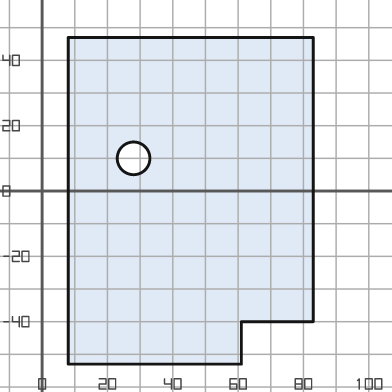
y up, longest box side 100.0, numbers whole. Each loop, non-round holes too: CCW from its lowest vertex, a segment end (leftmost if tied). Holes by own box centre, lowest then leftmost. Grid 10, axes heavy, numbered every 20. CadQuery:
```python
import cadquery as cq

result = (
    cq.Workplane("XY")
    .moveTo(8.0, -53.0)
    .lineTo(61.0, -53.0)
    .lineTo(61.0, -40.0)
    .lineTo(83.0, -40.0)
    .lineTo(83.0, 47.0)
    .lineTo(8.0, 47.0)
    .close()
    .moveTo(28.0, 10.0)
    .circle(5.0)
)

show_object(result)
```